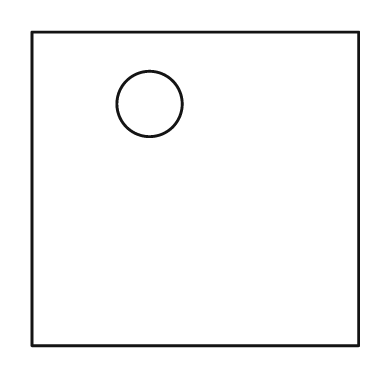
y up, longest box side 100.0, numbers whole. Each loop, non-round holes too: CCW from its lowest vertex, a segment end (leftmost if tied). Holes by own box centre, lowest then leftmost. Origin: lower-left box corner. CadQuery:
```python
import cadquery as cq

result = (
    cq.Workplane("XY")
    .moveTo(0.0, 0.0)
    .lineTo(100.0, 0.0)
    .lineTo(100.0, 96.0)
    .lineTo(0.0, 96.0)
    .close()
    .moveTo(36.0, 74.0)
    .circle(10.0)
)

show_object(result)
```